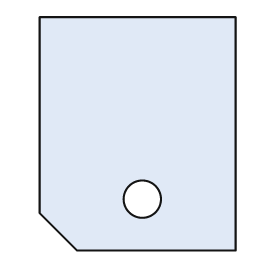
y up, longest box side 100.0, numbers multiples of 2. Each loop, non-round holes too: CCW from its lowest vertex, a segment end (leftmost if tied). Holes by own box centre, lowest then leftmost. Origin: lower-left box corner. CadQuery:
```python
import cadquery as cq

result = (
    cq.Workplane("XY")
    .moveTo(16.0, 0.0)
    .lineTo(84.0, 0.0)
    .lineTo(84.0, 100.0)
    .lineTo(0.0, 100.0)
    .lineTo(0.0, 16.0)
    .close()
    .moveTo(44.0, 22.0)
    .circle(8.0)
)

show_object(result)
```